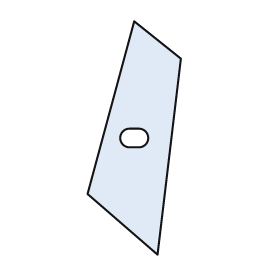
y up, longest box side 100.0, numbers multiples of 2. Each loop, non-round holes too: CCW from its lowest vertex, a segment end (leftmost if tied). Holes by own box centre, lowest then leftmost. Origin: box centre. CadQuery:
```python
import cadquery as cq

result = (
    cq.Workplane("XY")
    .moveTo(10.0, -50.0)
    .lineTo(20.0, 34.0)
    .lineTo(0.0, 50.0)
    .lineTo(-20.0, -24.0)
    .close()
    .moveTo(-2.0, -4.0)
    .lineTo(2.0, -4.0)
    .threePointArc((6.0, 0.0), (2.0, 4.0))
    .lineTo(-2.0, 4.0)
    .threePointArc((-6.0, 0.0), (-2.0, -4.0))
    .close()
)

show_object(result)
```